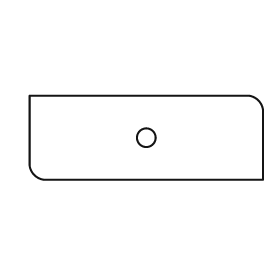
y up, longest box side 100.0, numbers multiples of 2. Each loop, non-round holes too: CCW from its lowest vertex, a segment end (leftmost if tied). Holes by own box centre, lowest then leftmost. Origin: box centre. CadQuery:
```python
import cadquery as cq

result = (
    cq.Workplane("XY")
    .moveTo(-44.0, -18.0)
    .lineTo(50.0, -18.0)
    .lineTo(50.0, 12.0)
    .threePointArc((48.0, 16.0), (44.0, 18.0))
    .lineTo(-50.0, 18.0)
    .lineTo(-50.0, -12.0)
    .threePointArc((-48.0, -16.0), (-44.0, -18.0))
    .close()
    .moveTo(0.0, 0.0)
    .circle(4.0)
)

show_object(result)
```